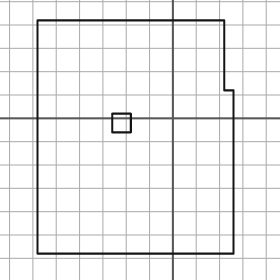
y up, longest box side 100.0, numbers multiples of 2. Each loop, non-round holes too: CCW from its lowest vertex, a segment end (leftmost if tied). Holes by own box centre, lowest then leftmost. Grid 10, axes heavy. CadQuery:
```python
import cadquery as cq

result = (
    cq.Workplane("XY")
    .moveTo(-58.0, -58.0)
    .lineTo(26.0, -58.0)
    .lineTo(26.0, 12.0)
    .lineTo(22.0, 12.0)
    .lineTo(22.0, 42.0)
    .lineTo(-58.0, 42.0)
    .close()
    .moveTo(-26.0, -6.0)
    .lineTo(-18.0, -6.0)
    .lineTo(-18.0, 2.0)
    .lineTo(-26.0, 2.0)
    .close()
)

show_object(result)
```